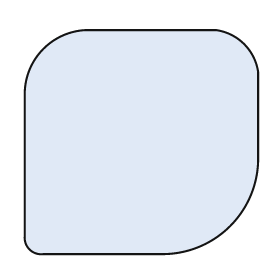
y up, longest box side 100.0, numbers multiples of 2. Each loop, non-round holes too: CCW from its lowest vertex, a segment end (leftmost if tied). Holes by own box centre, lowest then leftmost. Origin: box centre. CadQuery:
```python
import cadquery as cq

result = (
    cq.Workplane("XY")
    .moveTo(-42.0, -48.0)
    .lineTo(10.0, -48.0)
    .threePointArc((38.0, -36.0), (50.0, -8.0))
    .lineTo(50.0, 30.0)
    .threePointArc((44.0, 42.0), (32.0, 48.0))
    .lineTo(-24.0, 48.0)
    .threePointArc((-42.0, 40.0), (-50.0, 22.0))
    .lineTo(-50.0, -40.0)
    .threePointArc((-48.0, -46.0), (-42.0, -48.0))
    .close()
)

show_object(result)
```